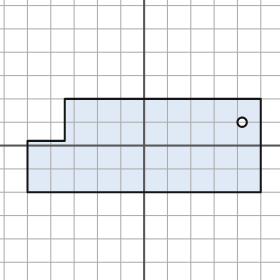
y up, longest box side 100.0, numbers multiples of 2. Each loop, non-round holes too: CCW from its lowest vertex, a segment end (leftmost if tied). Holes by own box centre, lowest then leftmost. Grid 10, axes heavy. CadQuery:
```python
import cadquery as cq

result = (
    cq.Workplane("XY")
    .moveTo(-50.0, -20.0)
    .lineTo(50.0, -20.0)
    .lineTo(50.0, 20.0)
    .lineTo(-34.0, 20.0)
    .lineTo(-34.0, 2.0)
    .lineTo(-50.0, 2.0)
    .close()
    .moveTo(42.0, 10.0)
    .circle(2.0)
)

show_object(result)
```